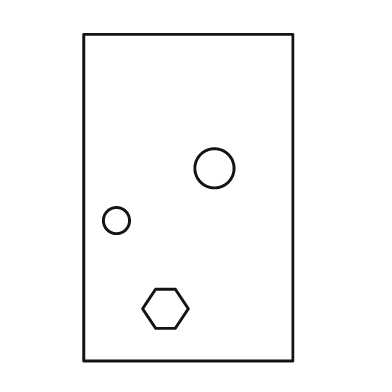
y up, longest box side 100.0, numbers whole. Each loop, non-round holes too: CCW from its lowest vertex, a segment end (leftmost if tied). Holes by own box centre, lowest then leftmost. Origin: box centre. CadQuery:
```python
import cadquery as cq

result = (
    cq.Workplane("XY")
    .moveTo(-32.0, -50.0)
    .lineTo(32.0, -50.0)
    .lineTo(32.0, 50.0)
    .lineTo(-32.0, 50.0)
    .close()
    .moveTo(-10.0, -40.0)
    .lineTo(-4.0, -40.0)
    .lineTo(0.0, -34.0)
    .lineTo(-4.0, -28.0)
    .lineTo(-10.0, -28.0)
    .lineTo(-14.0, -34.0)
    .close()
    .moveTo(-22.0, -7.0)
    .circle(4.0)
    .moveTo(8.0, 9.0)
    .circle(6.0)
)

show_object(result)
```